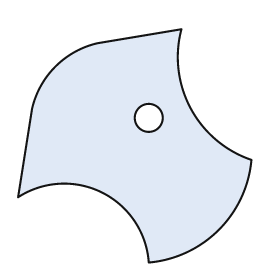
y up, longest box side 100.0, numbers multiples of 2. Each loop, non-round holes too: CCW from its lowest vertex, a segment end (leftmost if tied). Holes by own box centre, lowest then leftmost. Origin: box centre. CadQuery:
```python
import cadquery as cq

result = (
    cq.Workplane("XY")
    .moveTo(6.0, -50.0)
    .threePointArc((36.0, -36.0), (50.0, -6.0))
    .threePointArc((24.0, 16.0), (20.0, 50.0))
    .lineTo(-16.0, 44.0)
    .threePointArc((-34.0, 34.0), (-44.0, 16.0))
    .lineTo(-50.0, -22.0)
    .threePointArc((-14.0, -20.0), (6.0, -50.0))
    .close()
    .moveTo(6.0, 12.0)
    .circle(6.0)
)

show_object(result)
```